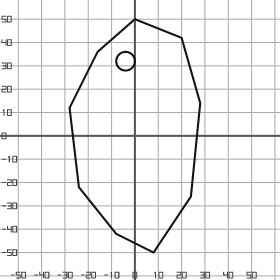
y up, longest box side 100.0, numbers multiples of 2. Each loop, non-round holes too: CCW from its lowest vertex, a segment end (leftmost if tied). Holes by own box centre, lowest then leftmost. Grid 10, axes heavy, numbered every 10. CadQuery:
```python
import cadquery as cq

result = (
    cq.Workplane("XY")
    .moveTo(8.0, -50.0)
    .lineTo(24.0, -26.0)
    .lineTo(28.0, 14.0)
    .lineTo(20.0, 42.0)
    .lineTo(0.0, 50.0)
    .lineTo(-16.0, 36.0)
    .lineTo(-28.0, 12.0)
    .lineTo(-24.0, -22.0)
    .lineTo(-8.0, -42.0)
    .close()
    .moveTo(-4.0, 32.0)
    .circle(4.0)
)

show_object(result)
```